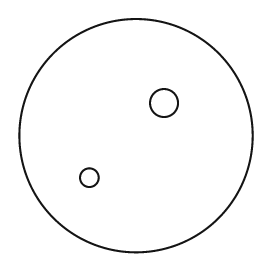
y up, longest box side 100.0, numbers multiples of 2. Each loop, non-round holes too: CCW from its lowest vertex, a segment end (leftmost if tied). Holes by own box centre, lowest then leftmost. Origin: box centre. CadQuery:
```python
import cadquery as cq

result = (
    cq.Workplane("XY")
    .moveTo(0.0, 0.0)
    .circle(50.0)
    .moveTo(-20.0, -18.0)
    .circle(4.0)
    .moveTo(12.0, 14.0)
    .circle(6.0)
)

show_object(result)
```